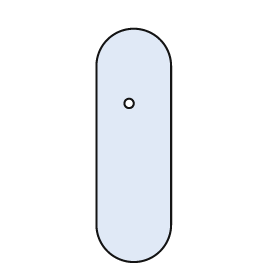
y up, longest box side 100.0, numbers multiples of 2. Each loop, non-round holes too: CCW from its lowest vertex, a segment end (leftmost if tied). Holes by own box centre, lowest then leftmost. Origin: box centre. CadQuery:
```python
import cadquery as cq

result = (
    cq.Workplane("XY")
    .moveTo(-16.0, -34.0)
    .threePointArc((0.0, -50.0), (16.0, -34.0))
    .lineTo(16.0, 34.0)
    .threePointArc((0.0, 50.0), (-16.0, 34.0))
    .close()
    .moveTo(-2.0, 18.0)
    .circle(2.0)
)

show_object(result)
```